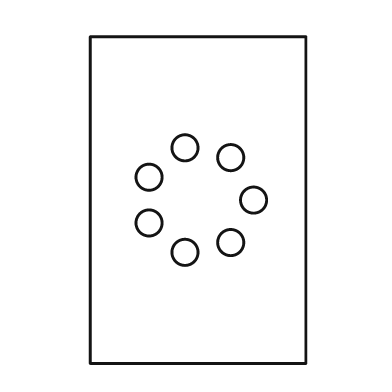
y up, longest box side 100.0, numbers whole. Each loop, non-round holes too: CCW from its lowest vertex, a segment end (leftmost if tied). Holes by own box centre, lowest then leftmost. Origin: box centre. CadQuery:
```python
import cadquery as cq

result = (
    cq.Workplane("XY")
    .moveTo(-33.0, -50.0)
    .lineTo(33.0, -50.0)
    .lineTo(33.0, 50.0)
    .lineTo(-33.0, 50.0)
    .close()
    .moveTo(-4.0, -16.0)
    .circle(4.0)
    .moveTo(10.0, -13.0)
    .circle(4.0)
    .moveTo(-15.0, -7.0)
    .circle(4.0)
    .moveTo(17.0, 0.0)
    .circle(4.0)
    .moveTo(-15.0, 7.0)
    .circle(4.0)
    .moveTo(10.0, 13.0)
    .circle(4.0)
    .moveTo(-4.0, 16.0)
    .circle(4.0)
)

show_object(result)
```